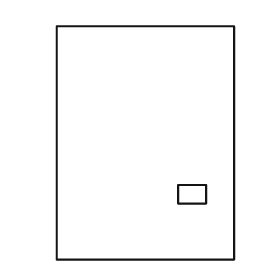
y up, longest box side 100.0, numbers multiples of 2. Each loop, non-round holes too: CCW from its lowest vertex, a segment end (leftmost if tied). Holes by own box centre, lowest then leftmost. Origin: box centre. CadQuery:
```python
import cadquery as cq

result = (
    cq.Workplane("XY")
    .moveTo(-38.0, -50.0)
    .lineTo(38.0, -50.0)
    .lineTo(38.0, 50.0)
    .lineTo(-38.0, 50.0)
    .close()
    .moveTo(14.0, -26.0)
    .lineTo(26.0, -26.0)
    .lineTo(26.0, -18.0)
    .lineTo(14.0, -18.0)
    .close()
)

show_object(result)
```